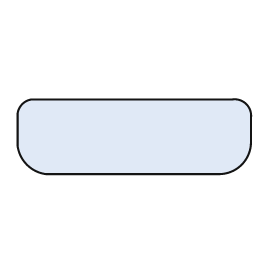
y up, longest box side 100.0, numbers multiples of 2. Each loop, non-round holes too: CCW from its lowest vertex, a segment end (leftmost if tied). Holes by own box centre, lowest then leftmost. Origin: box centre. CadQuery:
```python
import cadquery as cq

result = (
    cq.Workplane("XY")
    .moveTo(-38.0, -16.0)
    .lineTo(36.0, -16.0)
    .threePointArc((46.0, -12.0), (50.0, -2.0))
    .lineTo(50.0, 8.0)
    .threePointArc((48.0, 14.0), (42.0, 16.0))
    .lineTo(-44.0, 16.0)
    .threePointArc((-48.0, 14.0), (-50.0, 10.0))
    .lineTo(-50.0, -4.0)
    .threePointArc((-46.0, -12.0), (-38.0, -16.0))
    .close()
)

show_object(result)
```